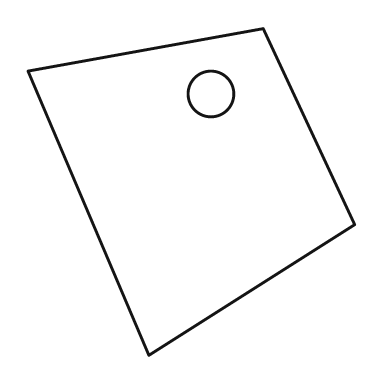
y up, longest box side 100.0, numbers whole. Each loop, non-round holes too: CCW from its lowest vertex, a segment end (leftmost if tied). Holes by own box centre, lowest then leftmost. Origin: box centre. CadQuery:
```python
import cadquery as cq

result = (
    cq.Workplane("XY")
    .moveTo(-13.0, -50.0)
    .lineTo(50.0, -10.0)
    .lineTo(22.0, 50.0)
    .lineTo(-50.0, 37.0)
    .close()
    .moveTo(6.0, 30.0)
    .circle(7.0)
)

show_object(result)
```